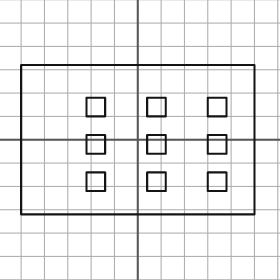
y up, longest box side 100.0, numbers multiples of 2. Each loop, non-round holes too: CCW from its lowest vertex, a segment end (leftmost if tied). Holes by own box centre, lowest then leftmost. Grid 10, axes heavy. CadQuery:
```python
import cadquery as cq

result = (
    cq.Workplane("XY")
    .moveTo(-50.0, -32.0)
    .lineTo(50.0, -32.0)
    .lineTo(50.0, 32.0)
    .lineTo(-50.0, 32.0)
    .close()
    .moveTo(-22.0, -22.0)
    .lineTo(-14.0, -22.0)
    .lineTo(-14.0, -14.0)
    .lineTo(-22.0, -14.0)
    .close()
    .moveTo(4.0, -22.0)
    .lineTo(12.0, -22.0)
    .lineTo(12.0, -14.0)
    .lineTo(4.0, -14.0)
    .close()
    .moveTo(30.0, -22.0)
    .lineTo(38.0, -22.0)
    .lineTo(38.0, -14.0)
    .lineTo(30.0, -14.0)
    .close()
    .moveTo(-22.0, -6.0)
    .lineTo(-14.0, -6.0)
    .lineTo(-14.0, 2.0)
    .lineTo(-22.0, 2.0)
    .close()
    .moveTo(4.0, -6.0)
    .lineTo(12.0, -6.0)
    .lineTo(12.0, 2.0)
    .lineTo(4.0, 2.0)
    .close()
    .moveTo(30.0, -6.0)
    .lineTo(38.0, -6.0)
    .lineTo(38.0, 2.0)
    .lineTo(30.0, 2.0)
    .close()
    .moveTo(-22.0, 10.0)
    .lineTo(-14.0, 10.0)
    .lineTo(-14.0, 18.0)
    .lineTo(-22.0, 18.0)
    .close()
    .moveTo(4.0, 10.0)
    .lineTo(12.0, 10.0)
    .lineTo(12.0, 18.0)
    .lineTo(4.0, 18.0)
    .close()
    .moveTo(30.0, 10.0)
    .lineTo(38.0, 10.0)
    .lineTo(38.0, 18.0)
    .lineTo(30.0, 18.0)
    .close()
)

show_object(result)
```